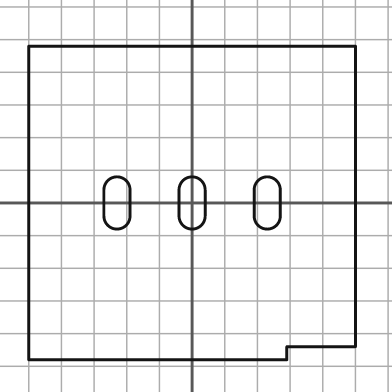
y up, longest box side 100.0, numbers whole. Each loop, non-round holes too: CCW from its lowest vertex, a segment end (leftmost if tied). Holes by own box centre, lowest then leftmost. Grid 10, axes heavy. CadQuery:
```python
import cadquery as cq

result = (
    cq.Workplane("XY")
    .moveTo(-50.0, -48.0)
    .lineTo(29.0, -48.0)
    .lineTo(29.0, -44.0)
    .lineTo(50.0, -44.0)
    .lineTo(50.0, 48.0)
    .lineTo(-50.0, 48.0)
    .close()
    .moveTo(-27.0, -4.0)
    .threePointArc((-23.0, -8.0), (-19.0, -4.0))
    .lineTo(-19.0, 4.0)
    .threePointArc((-23.0, 8.0), (-27.0, 4.0))
    .close()
    .moveTo(-4.0, -4.0)
    .threePointArc((0.0, -8.0), (4.0, -4.0))
    .lineTo(4.0, 4.0)
    .threePointArc((0.0, 8.0), (-4.0, 4.0))
    .close()
    .moveTo(19.0, -4.0)
    .threePointArc((23.0, -8.0), (27.0, -4.0))
    .lineTo(27.0, 4.0)
    .threePointArc((23.0, 8.0), (19.0, 4.0))
    .close()
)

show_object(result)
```